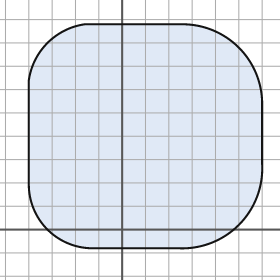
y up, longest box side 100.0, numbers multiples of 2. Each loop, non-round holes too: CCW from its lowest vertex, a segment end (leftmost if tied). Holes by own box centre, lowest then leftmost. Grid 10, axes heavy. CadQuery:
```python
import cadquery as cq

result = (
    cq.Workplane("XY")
    .moveTo(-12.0, -8.0)
    .lineTo(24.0, -8.0)
    .threePointArc((50.0, 2.0), (60.0, 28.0))
    .lineTo(60.0, 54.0)
    .threePointArc((50.0, 78.0), (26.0, 88.0))
    .lineTo(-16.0, 88.0)
    .threePointArc((-32.0, 80.0), (-40.0, 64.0))
    .lineTo(-40.0, 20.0)
    .threePointArc((-32.0, 0.0), (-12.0, -8.0))
    .close()
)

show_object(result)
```